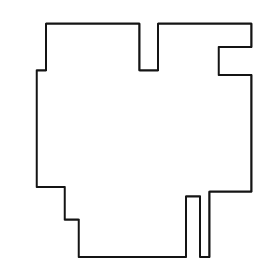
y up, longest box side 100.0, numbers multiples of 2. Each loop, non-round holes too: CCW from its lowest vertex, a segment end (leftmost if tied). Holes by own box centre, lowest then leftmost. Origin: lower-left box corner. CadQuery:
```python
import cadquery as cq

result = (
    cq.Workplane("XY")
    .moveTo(18.0, 0.0)
    .lineTo(64.0, 0.0)
    .lineTo(64.0, 26.0)
    .lineTo(70.0, 26.0)
    .lineTo(70.0, 0.0)
    .lineTo(74.0, 0.0)
    .lineTo(74.0, 28.0)
    .lineTo(92.0, 28.0)
    .lineTo(92.0, 78.0)
    .lineTo(78.0, 78.0)
    .lineTo(78.0, 90.0)
    .lineTo(92.0, 90.0)
    .lineTo(92.0, 100.0)
    .lineTo(52.0, 100.0)
    .lineTo(52.0, 80.0)
    .lineTo(44.0, 80.0)
    .lineTo(44.0, 100.0)
    .lineTo(4.0, 100.0)
    .lineTo(4.0, 80.0)
    .lineTo(0.0, 80.0)
    .lineTo(0.0, 30.0)
    .lineTo(12.0, 30.0)
    .lineTo(12.0, 16.0)
    .lineTo(18.0, 16.0)
    .close()
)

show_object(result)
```